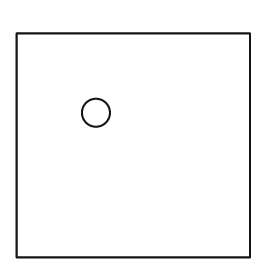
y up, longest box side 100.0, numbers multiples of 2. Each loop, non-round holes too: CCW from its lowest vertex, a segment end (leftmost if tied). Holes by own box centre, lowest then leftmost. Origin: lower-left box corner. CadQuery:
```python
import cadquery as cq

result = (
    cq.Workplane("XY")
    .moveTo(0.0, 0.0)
    .lineTo(100.0, 0.0)
    .lineTo(100.0, 96.0)
    .lineTo(0.0, 96.0)
    .close()
    .moveTo(34.0, 62.0)
    .circle(6.0)
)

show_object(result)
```